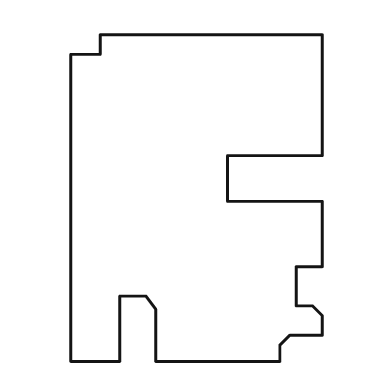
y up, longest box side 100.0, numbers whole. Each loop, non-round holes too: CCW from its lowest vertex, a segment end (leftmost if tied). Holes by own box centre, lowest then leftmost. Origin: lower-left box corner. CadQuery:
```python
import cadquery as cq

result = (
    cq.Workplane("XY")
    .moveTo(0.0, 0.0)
    .lineTo(15.0, 0.0)
    .lineTo(15.0, 20.0)
    .lineTo(23.0, 20.0)
    .lineTo(26.0, 16.0)
    .lineTo(26.0, 0.0)
    .lineTo(64.0, 0.0)
    .lineTo(64.0, 5.0)
    .lineTo(67.0, 8.0)
    .lineTo(77.0, 8.0)
    .lineTo(77.0, 14.0)
    .lineTo(74.0, 17.0)
    .lineTo(69.0, 17.0)
    .lineTo(69.0, 29.0)
    .lineTo(77.0, 29.0)
    .lineTo(77.0, 49.0)
    .lineTo(48.0, 49.0)
    .lineTo(48.0, 63.0)
    .lineTo(77.0, 63.0)
    .lineTo(77.0, 100.0)
    .lineTo(9.0, 100.0)
    .lineTo(9.0, 94.0)
    .lineTo(0.0, 94.0)
    .close()
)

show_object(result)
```